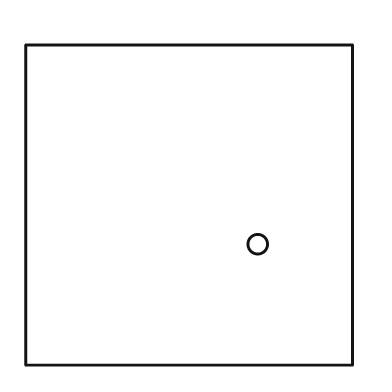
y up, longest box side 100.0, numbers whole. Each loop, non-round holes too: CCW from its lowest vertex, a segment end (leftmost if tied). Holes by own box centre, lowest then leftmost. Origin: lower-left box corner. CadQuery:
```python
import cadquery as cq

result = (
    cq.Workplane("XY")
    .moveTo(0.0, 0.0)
    .lineTo(100.0, 0.0)
    .lineTo(100.0, 98.0)
    .lineTo(0.0, 98.0)
    .close()
    .moveTo(71.0, 37.0)
    .circle(3.0)
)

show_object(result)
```